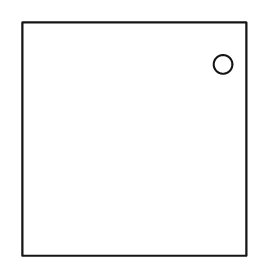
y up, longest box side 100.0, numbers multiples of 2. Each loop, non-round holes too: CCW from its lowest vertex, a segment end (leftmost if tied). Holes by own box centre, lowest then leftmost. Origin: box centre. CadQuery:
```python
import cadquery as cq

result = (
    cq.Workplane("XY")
    .moveTo(-48.0, -50.0)
    .lineTo(48.0, -50.0)
    .lineTo(48.0, 50.0)
    .lineTo(-48.0, 50.0)
    .close()
    .moveTo(38.0, 32.0)
    .circle(4.0)
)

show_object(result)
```